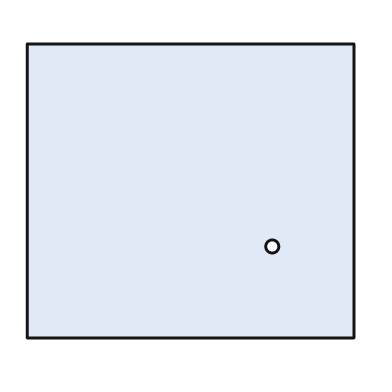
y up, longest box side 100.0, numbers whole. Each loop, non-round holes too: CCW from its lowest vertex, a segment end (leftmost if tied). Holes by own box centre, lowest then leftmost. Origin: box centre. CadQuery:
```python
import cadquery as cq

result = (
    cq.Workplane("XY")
    .moveTo(-50.0, -45.0)
    .lineTo(50.0, -45.0)
    .lineTo(50.0, 45.0)
    .lineTo(-50.0, 45.0)
    .close()
    .moveTo(25.0, -17.0)
    .circle(2.0)
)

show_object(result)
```